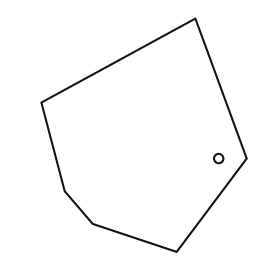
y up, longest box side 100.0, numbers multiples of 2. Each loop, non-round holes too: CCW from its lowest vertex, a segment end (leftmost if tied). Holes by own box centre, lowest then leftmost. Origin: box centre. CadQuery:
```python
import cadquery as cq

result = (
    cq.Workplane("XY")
    .moveTo(14.0, -50.0)
    .lineTo(44.0, -10.0)
    .lineTo(22.0, 50.0)
    .lineTo(-44.0, 14.0)
    .lineTo(-34.0, -24.0)
    .lineTo(-22.0, -38.0)
    .close()
    .moveTo(32.0, -10.0)
    .circle(2.0)
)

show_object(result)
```